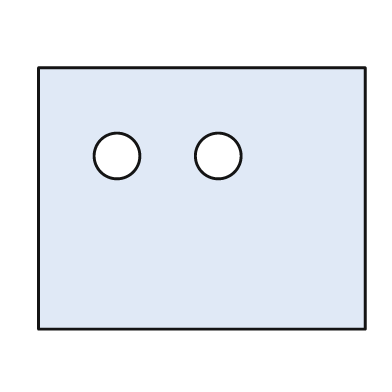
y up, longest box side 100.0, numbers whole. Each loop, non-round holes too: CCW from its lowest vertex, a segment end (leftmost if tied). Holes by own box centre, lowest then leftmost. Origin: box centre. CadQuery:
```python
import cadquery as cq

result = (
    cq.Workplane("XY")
    .moveTo(-50.0, -40.0)
    .lineTo(50.0, -40.0)
    .lineTo(50.0, 40.0)
    .lineTo(-50.0, 40.0)
    .close()
    .moveTo(-26.0, 13.0)
    .circle(7.0)
    .moveTo(5.0, 13.0)
    .circle(7.0)
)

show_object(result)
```